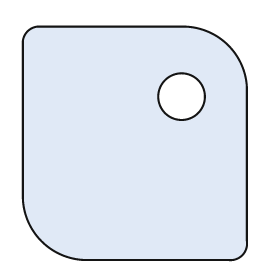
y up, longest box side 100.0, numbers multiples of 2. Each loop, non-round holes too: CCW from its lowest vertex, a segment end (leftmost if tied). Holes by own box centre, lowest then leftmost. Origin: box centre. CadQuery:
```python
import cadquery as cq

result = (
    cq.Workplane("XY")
    .moveTo(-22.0, -50.0)
    .lineTo(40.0, -50.0)
    .threePointArc((46.0, -48.0), (48.0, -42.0))
    .lineTo(48.0, 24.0)
    .threePointArc((40.0, 42.0), (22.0, 50.0))
    .lineTo(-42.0, 50.0)
    .threePointArc((-46.0, 48.0), (-48.0, 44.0))
    .lineTo(-48.0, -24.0)
    .threePointArc((-40.0, -42.0), (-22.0, -50.0))
    .close()
    .moveTo(20.0, 20.0)
    .circle(10.0)
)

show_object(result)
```